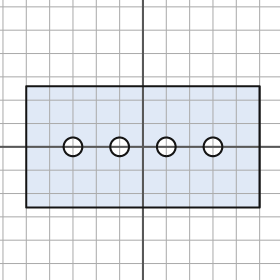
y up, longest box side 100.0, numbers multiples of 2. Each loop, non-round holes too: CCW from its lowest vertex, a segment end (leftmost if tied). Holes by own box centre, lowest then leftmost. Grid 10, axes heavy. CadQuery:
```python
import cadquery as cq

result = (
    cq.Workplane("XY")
    .moveTo(-50.0, -26.0)
    .lineTo(50.0, -26.0)
    .lineTo(50.0, 26.0)
    .lineTo(-50.0, 26.0)
    .close()
    .moveTo(-30.0, 0.0)
    .circle(4.0)
    .moveTo(-10.0, 0.0)
    .circle(4.0)
    .moveTo(10.0, 0.0)
    .circle(4.0)
    .moveTo(30.0, 0.0)
    .circle(4.0)
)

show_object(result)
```